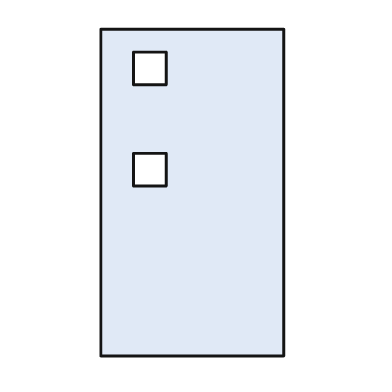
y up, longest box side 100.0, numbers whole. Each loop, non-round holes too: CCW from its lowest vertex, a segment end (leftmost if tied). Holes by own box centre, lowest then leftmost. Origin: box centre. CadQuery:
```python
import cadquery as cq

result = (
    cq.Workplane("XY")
    .moveTo(-28.0, -50.0)
    .lineTo(28.0, -50.0)
    .lineTo(28.0, 50.0)
    .lineTo(-28.0, 50.0)
    .close()
    .moveTo(-18.0, 2.0)
    .lineTo(-8.0, 2.0)
    .lineTo(-8.0, 12.0)
    .lineTo(-18.0, 12.0)
    .close()
    .moveTo(-18.0, 33.0)
    .lineTo(-8.0, 33.0)
    .lineTo(-8.0, 43.0)
    .lineTo(-18.0, 43.0)
    .close()
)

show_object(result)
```